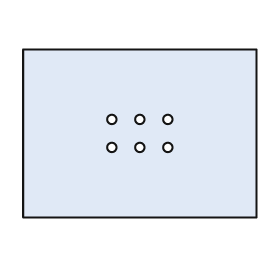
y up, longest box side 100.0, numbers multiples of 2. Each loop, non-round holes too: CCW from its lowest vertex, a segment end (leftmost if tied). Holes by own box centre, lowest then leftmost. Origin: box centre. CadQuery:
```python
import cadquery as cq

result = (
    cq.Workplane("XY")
    .moveTo(-50.0, -36.0)
    .lineTo(50.0, -36.0)
    .lineTo(50.0, 36.0)
    .lineTo(-50.0, 36.0)
    .close()
    .moveTo(-12.0, -6.0)
    .circle(2.0)
    .moveTo(0.0, -6.0)
    .circle(2.0)
    .moveTo(12.0, -6.0)
    .circle(2.0)
    .moveTo(-12.0, 6.0)
    .circle(2.0)
    .moveTo(0.0, 6.0)
    .circle(2.0)
    .moveTo(12.0, 6.0)
    .circle(2.0)
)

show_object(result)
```